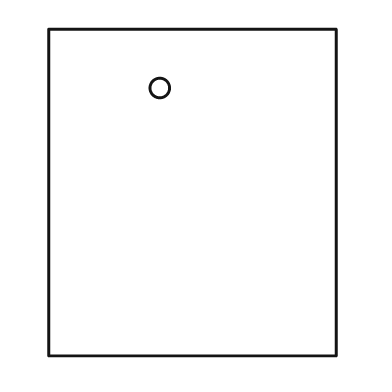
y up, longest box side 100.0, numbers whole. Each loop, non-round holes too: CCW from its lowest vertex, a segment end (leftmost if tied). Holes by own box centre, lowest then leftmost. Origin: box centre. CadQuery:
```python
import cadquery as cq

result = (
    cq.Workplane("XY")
    .moveTo(-44.0, -50.0)
    .lineTo(44.0, -50.0)
    .lineTo(44.0, 50.0)
    .lineTo(-44.0, 50.0)
    .close()
    .moveTo(-10.0, 32.0)
    .circle(3.0)
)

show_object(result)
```